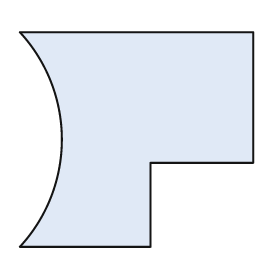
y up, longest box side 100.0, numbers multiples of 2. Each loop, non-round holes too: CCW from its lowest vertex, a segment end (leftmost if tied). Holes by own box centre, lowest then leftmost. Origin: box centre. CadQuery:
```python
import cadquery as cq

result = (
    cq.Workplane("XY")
    .moveTo(-50.0, -46.0)
    .lineTo(6.0, -46.0)
    .lineTo(6.0, -10.0)
    .lineTo(50.0, -10.0)
    .lineTo(50.0, 46.0)
    .lineTo(-50.0, 46.0)
    .threePointArc((-32.0, 0.0), (-50.0, -46.0))
    .close()
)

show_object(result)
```